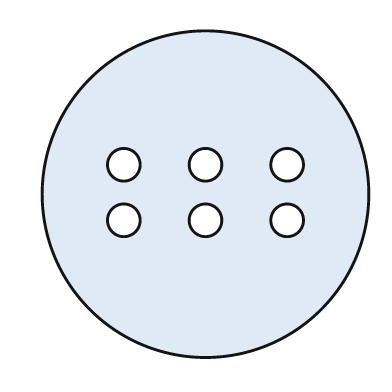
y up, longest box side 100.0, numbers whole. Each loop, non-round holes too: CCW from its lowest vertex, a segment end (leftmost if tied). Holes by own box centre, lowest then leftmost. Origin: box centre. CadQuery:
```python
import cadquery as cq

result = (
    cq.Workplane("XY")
    .moveTo(0.0, 0.0)
    .circle(50.0)
    .moveTo(-25.0, -8.0)
    .circle(5.0)
    .moveTo(0.0, -8.0)
    .circle(5.0)
    .moveTo(25.0, -8.0)
    .circle(5.0)
    .moveTo(-25.0, 9.0)
    .circle(5.0)
    .moveTo(0.0, 9.0)
    .circle(5.0)
    .moveTo(25.0, 9.0)
    .circle(5.0)
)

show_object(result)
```